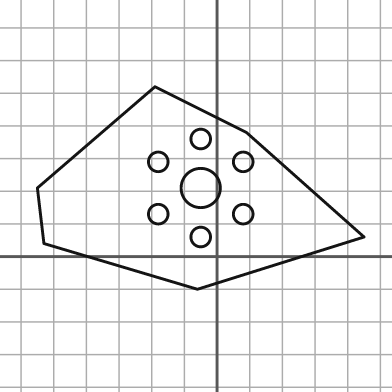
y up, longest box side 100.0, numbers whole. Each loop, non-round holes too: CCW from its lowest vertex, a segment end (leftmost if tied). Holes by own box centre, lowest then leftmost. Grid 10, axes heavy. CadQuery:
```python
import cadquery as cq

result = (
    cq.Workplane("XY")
    .moveTo(-6.0, -10.0)
    .lineTo(45.0, 6.0)
    .lineTo(9.0, 38.0)
    .lineTo(-19.0, 52.0)
    .lineTo(-55.0, 21.0)
    .lineTo(-53.0, 4.0)
    .close()
    .moveTo(-5.0, 6.0)
    .circle(3.0)
    .moveTo(-18.0, 13.0)
    .circle(3.0)
    .moveTo(8.0, 13.0)
    .circle(3.0)
    .moveTo(-5.0, 21.0)
    .circle(6.0)
    .moveTo(-18.0, 29.0)
    .circle(3.0)
    .moveTo(8.0, 29.0)
    .circle(3.0)
    .moveTo(-5.0, 36.0)
    .circle(3.0)
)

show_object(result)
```